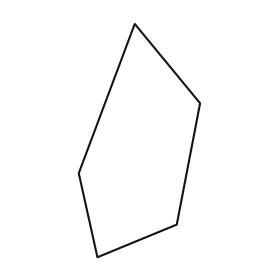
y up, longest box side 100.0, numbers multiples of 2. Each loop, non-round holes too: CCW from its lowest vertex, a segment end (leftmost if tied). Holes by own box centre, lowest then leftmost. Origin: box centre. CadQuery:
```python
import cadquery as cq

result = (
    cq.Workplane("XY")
    .moveTo(-18.0, -50.0)
    .lineTo(16.0, -36.0)
    .lineTo(26.0, 16.0)
    .lineTo(-2.0, 50.0)
    .lineTo(-26.0, -14.0)
    .close()
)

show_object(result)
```